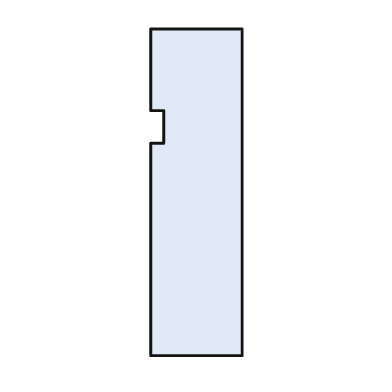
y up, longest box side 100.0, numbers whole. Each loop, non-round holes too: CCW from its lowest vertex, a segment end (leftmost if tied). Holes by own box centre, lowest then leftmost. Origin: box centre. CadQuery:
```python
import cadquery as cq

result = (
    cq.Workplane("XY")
    .moveTo(-14.0, -50.0)
    .lineTo(14.0, -50.0)
    .lineTo(14.0, 50.0)
    .lineTo(-14.0, 50.0)
    .lineTo(-14.0, 25.0)
    .lineTo(-10.0, 25.0)
    .lineTo(-10.0, 15.0)
    .lineTo(-14.0, 15.0)
    .close()
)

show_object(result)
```